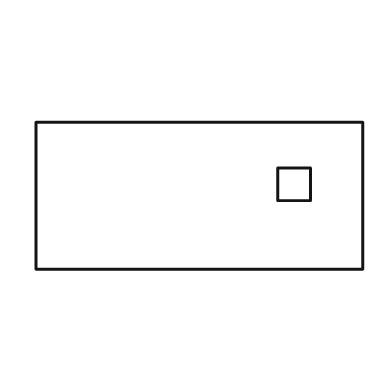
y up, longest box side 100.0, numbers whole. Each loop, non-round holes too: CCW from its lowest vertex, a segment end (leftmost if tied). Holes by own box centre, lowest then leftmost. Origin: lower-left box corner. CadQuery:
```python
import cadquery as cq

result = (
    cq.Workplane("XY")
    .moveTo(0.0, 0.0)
    .lineTo(100.0, 0.0)
    .lineTo(100.0, 45.0)
    .lineTo(0.0, 45.0)
    .close()
    .moveTo(74.0, 21.0)
    .lineTo(84.0, 21.0)
    .lineTo(84.0, 31.0)
    .lineTo(74.0, 31.0)
    .close()
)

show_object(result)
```